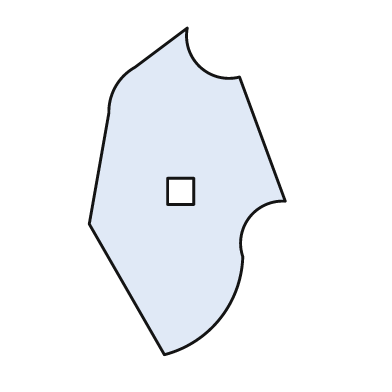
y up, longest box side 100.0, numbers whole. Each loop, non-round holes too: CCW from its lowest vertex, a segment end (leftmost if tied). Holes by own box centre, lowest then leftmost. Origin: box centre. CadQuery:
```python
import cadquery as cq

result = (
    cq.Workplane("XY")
    .moveTo(-7.0, -50.0)
    .threePointArc((10.0, -39.0), (17.0, -20.0))
    .threePointArc((19.0, -8.0), (30.0, -3.0))
    .lineTo(16.0, 35.0)
    .threePointArc((4.0, 38.0), (0.0, 50.0))
    .lineTo(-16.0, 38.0)
    .threePointArc((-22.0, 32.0), (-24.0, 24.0))
    .lineTo(-30.0, -10.0)
    .close()
    .moveTo(-6.0, -4.0)
    .lineTo(2.0, -4.0)
    .lineTo(2.0, 4.0)
    .lineTo(-6.0, 4.0)
    .close()
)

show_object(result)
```